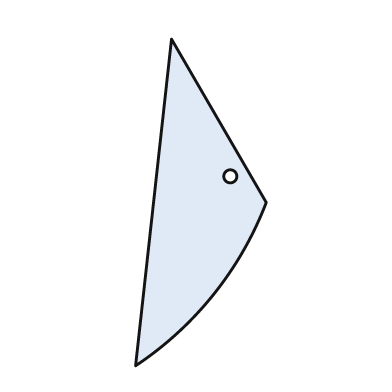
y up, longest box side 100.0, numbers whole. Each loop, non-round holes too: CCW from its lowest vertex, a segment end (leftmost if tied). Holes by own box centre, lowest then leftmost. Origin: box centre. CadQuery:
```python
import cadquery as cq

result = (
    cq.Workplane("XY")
    .moveTo(-20.0, -50.0)
    .threePointArc((4.0, -28.0), (20.0, 0.0))
    .lineTo(-9.0, 50.0)
    .close()
    .moveTo(9.0, 8.0)
    .circle(2.0)
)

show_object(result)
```